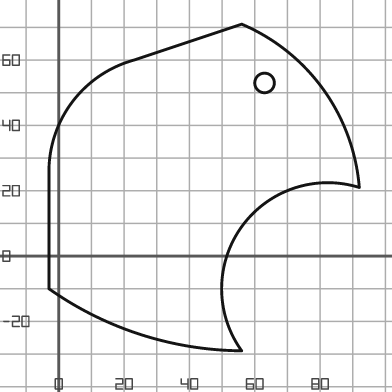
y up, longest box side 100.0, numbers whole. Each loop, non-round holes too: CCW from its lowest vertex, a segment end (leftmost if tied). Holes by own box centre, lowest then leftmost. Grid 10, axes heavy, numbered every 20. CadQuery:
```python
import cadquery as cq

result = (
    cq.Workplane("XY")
    .moveTo(56.0, -29.0)
    .threePointArc((56.0, 9.0), (92.0, 21.0))
    .threePointArc((81.0, 51.0), (56.0, 71.0))
    .lineTo(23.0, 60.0)
    .threePointArc((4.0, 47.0), (-3.0, 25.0))
    .lineTo(-3.0, -10.0)
    .threePointArc((25.0, -24.0), (56.0, -29.0))
    .close()
    .moveTo(63.0, 53.0)
    .circle(3.0)
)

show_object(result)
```